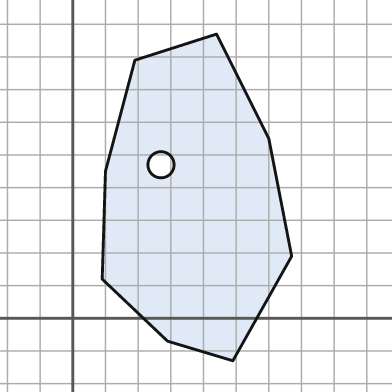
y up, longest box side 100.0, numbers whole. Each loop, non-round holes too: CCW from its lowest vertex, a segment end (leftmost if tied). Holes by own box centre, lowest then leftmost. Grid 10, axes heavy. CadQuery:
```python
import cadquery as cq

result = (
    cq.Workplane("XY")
    .moveTo(49.0, -13.0)
    .lineTo(67.0, 19.0)
    .lineTo(60.0, 55.0)
    .lineTo(44.0, 87.0)
    .lineTo(19.0, 79.0)
    .lineTo(10.0, 45.0)
    .lineTo(9.0, 12.0)
    .lineTo(29.0, -7.0)
    .close()
    .moveTo(27.0, 47.0)
    .circle(4.0)
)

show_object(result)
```